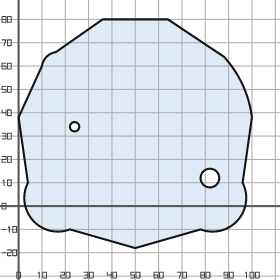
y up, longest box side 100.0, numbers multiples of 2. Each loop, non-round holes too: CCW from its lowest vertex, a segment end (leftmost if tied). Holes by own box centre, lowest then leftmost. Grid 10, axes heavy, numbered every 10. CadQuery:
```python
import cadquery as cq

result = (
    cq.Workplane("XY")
    .moveTo(50.0, -18.0)
    .lineTo(78.0, -10.0)
    .threePointArc((94.0, -6.0), (96.0, 10.0))
    .lineTo(100.0, 38.0)
    .threePointArc((96.0, 52.0), (88.0, 64.0))
    .lineTo(64.0, 80.0)
    .lineTo(36.0, 80.0)
    .lineTo(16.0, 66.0)
    .threePointArc((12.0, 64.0), (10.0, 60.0))
    .lineTo(0.0, 38.0)
    .lineTo(4.0, 10.0)
    .threePointArc((6.0, -6.0), (22.0, -10.0))
    .close()
    .moveTo(82.0, 12.0)
    .circle(4.0)
    .moveTo(24.0, 34.0)
    .circle(2.0)
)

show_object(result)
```